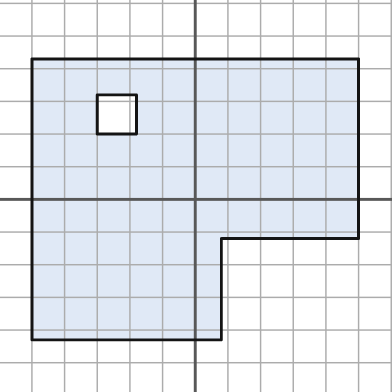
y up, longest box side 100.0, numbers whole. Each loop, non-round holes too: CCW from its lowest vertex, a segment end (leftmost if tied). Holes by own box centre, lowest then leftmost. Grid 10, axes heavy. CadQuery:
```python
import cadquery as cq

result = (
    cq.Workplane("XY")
    .moveTo(-50.0, -43.0)
    .lineTo(8.0, -43.0)
    .lineTo(8.0, -12.0)
    .lineTo(50.0, -12.0)
    .lineTo(50.0, 43.0)
    .lineTo(-50.0, 43.0)
    .close()
    .moveTo(-30.0, 20.0)
    .lineTo(-18.0, 20.0)
    .lineTo(-18.0, 32.0)
    .lineTo(-30.0, 32.0)
    .close()
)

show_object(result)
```